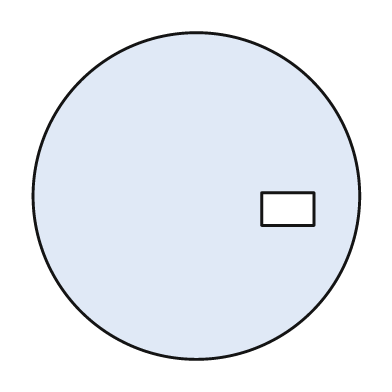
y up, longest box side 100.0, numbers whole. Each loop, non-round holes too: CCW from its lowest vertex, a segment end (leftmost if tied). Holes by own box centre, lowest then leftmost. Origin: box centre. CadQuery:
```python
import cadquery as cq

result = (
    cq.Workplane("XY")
    .moveTo(0.0, 0.0)
    .circle(50.0)
    .moveTo(20.0, -9.0)
    .lineTo(36.0, -9.0)
    .lineTo(36.0, 1.0)
    .lineTo(20.0, 1.0)
    .close()
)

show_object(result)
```